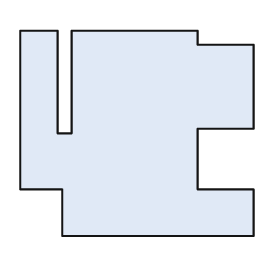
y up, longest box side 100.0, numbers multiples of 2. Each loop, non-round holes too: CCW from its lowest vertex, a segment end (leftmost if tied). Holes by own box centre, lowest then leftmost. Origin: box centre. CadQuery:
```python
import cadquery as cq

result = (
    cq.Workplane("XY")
    .moveTo(-32.0, -44.0)
    .lineTo(50.0, -44.0)
    .lineTo(50.0, -24.0)
    .lineTo(26.0, -24.0)
    .lineTo(26.0, 2.0)
    .lineTo(50.0, 2.0)
    .lineTo(50.0, 38.0)
    .lineTo(26.0, 38.0)
    .lineTo(26.0, 44.0)
    .lineTo(-28.0, 44.0)
    .lineTo(-28.0, 0.0)
    .lineTo(-34.0, 0.0)
    .lineTo(-34.0, 44.0)
    .lineTo(-50.0, 44.0)
    .lineTo(-50.0, -24.0)
    .lineTo(-32.0, -24.0)
    .close()
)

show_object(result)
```